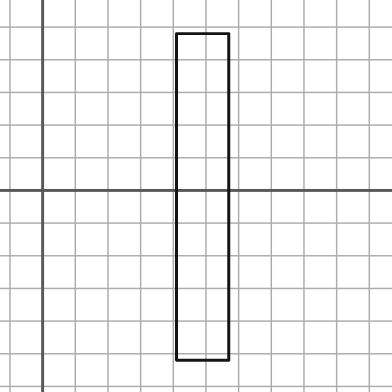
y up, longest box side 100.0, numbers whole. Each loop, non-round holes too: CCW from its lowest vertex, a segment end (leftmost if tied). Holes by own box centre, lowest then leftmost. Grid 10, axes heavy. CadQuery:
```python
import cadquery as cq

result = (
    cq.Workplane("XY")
    .moveTo(41.0, -52.0)
    .lineTo(57.0, -52.0)
    .lineTo(57.0, 48.0)
    .lineTo(41.0, 48.0)
    .close()
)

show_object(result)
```